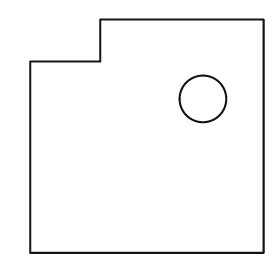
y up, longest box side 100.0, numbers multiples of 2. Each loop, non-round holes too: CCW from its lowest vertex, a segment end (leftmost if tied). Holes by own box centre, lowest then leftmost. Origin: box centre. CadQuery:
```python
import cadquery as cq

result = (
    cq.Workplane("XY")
    .moveTo(-50.0, -50.0)
    .lineTo(50.0, -50.0)
    .lineTo(50.0, 50.0)
    .lineTo(-20.0, 50.0)
    .lineTo(-20.0, 32.0)
    .lineTo(-50.0, 32.0)
    .close()
    .moveTo(24.0, 16.0)
    .circle(10.0)
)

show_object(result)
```